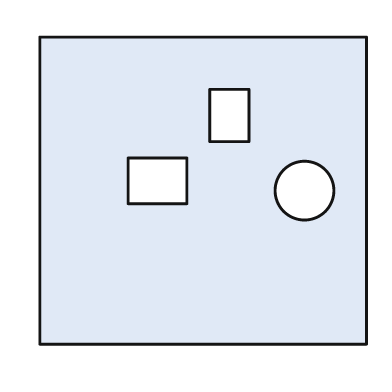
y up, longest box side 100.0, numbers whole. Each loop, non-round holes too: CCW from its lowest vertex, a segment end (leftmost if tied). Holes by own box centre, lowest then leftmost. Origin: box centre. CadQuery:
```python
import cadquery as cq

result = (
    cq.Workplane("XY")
    .moveTo(-50.0, -47.0)
    .lineTo(50.0, -47.0)
    .lineTo(50.0, 47.0)
    .lineTo(-50.0, 47.0)
    .close()
    .moveTo(31.0, 0.0)
    .circle(9.0)
    .moveTo(-23.0, -4.0)
    .lineTo(-5.0, -4.0)
    .lineTo(-5.0, 10.0)
    .lineTo(-23.0, 10.0)
    .close()
    .moveTo(2.0, 15.0)
    .lineTo(14.0, 15.0)
    .lineTo(14.0, 31.0)
    .lineTo(2.0, 31.0)
    .close()
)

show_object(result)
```